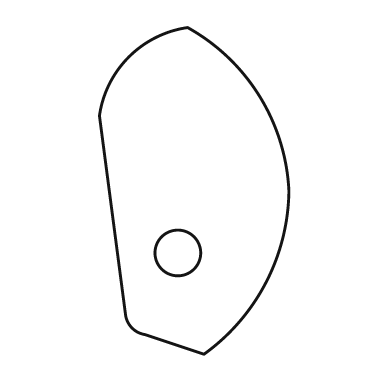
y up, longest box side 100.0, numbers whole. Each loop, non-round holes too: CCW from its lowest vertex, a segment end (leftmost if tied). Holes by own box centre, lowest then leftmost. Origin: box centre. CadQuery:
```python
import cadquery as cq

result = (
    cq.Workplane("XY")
    .moveTo(3.0, -50.0)
    .threePointArc((22.0, -28.0), (29.0, 0.0))
    .threePointArc((20.0, 29.0), (-2.0, 50.0))
    .threePointArc((-20.0, 41.0), (-29.0, 23.0))
    .lineTo(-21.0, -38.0)
    .threePointArc((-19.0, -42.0), (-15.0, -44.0))
    .close()
    .moveTo(-5.0, -19.0)
    .circle(7.0)
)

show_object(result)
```